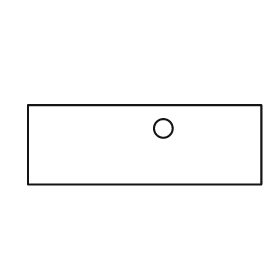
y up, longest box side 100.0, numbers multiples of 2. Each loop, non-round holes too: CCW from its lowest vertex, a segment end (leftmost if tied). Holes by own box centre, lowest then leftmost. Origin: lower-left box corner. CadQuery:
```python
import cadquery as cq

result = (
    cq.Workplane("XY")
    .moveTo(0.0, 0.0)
    .lineTo(100.0, 0.0)
    .lineTo(100.0, 34.0)
    .lineTo(0.0, 34.0)
    .close()
    .moveTo(58.0, 24.0)
    .circle(4.0)
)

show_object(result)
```